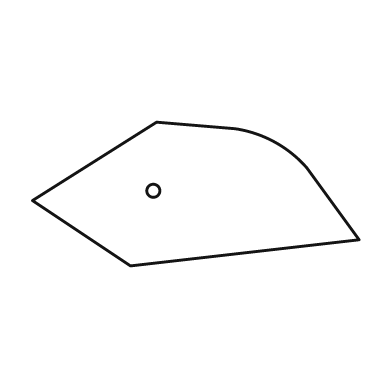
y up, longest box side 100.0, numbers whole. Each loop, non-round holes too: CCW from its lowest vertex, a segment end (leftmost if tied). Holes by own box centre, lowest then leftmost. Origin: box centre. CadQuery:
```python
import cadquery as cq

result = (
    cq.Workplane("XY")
    .moveTo(-20.0, -22.0)
    .lineTo(50.0, -14.0)
    .lineTo(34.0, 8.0)
    .threePointArc((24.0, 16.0), (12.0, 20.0))
    .lineTo(-12.0, 22.0)
    .lineTo(-50.0, -2.0)
    .close()
    .moveTo(-13.0, 1.0)
    .circle(2.0)
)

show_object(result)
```